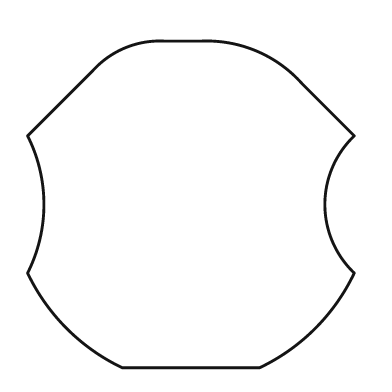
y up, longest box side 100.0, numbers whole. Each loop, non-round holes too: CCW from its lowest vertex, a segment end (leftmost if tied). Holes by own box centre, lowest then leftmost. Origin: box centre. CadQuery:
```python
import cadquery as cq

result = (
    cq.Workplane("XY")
    .moveTo(-21.0, -50.0)
    .lineTo(21.0, -50.0)
    .threePointArc((38.0, -38.0), (50.0, -21.0))
    .threePointArc((41.0, 0.0), (50.0, 21.0))
    .lineTo(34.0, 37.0)
    .threePointArc((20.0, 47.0), (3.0, 50.0))
    .lineTo(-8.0, 50.0)
    .threePointArc((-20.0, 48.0), (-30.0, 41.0))
    .lineTo(-50.0, 21.0)
    .threePointArc((-45.0, 0.0), (-50.0, -21.0))
    .threePointArc((-38.0, -38.0), (-21.0, -50.0))
    .close()
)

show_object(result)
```